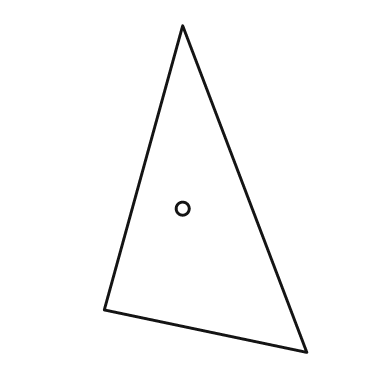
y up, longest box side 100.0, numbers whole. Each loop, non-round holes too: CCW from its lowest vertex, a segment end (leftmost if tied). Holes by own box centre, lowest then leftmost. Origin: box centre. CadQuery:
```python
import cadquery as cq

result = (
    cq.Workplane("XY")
    .moveTo(31.0, -50.0)
    .lineTo(-7.0, 50.0)
    .lineTo(-31.0, -37.0)
    .close()
    .moveTo(-7.0, -6.0)
    .circle(2.0)
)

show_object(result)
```